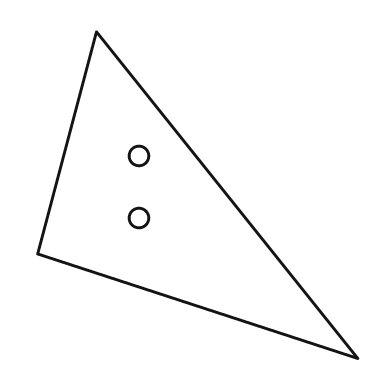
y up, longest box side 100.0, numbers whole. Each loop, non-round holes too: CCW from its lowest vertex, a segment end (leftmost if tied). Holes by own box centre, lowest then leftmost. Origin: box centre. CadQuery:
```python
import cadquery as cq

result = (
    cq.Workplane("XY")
    .moveTo(49.0, -50.0)
    .lineTo(-31.0, 50.0)
    .lineTo(-49.0, -18.0)
    .close()
    .moveTo(-18.0, -7.0)
    .circle(3.0)
    .moveTo(-18.0, 12.0)
    .circle(3.0)
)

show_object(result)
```